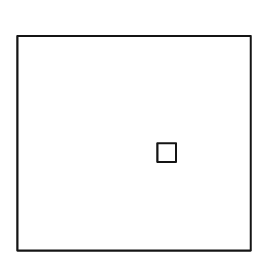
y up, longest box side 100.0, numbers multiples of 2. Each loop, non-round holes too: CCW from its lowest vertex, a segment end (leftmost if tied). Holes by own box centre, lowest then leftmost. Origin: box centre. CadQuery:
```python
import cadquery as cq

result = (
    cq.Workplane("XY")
    .moveTo(-50.0, -46.0)
    .lineTo(50.0, -46.0)
    .lineTo(50.0, 46.0)
    .lineTo(-50.0, 46.0)
    .close()
    .moveTo(10.0, -8.0)
    .lineTo(18.0, -8.0)
    .lineTo(18.0, 0.0)
    .lineTo(10.0, 0.0)
    .close()
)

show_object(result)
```